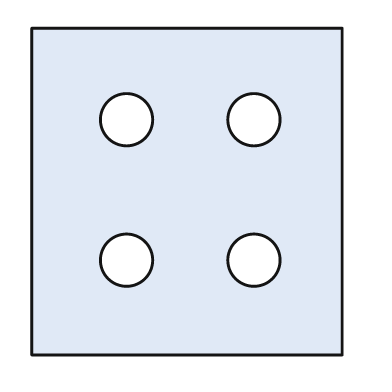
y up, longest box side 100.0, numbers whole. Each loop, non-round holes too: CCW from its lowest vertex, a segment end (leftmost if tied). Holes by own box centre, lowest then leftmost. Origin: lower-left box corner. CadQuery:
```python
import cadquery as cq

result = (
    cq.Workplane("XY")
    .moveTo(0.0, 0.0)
    .lineTo(95.0, 0.0)
    .lineTo(95.0, 100.0)
    .lineTo(0.0, 100.0)
    .close()
    .moveTo(29.0, 29.0)
    .circle(8.0)
    .moveTo(68.0, 29.0)
    .circle(8.0)
    .moveTo(29.0, 72.0)
    .circle(8.0)
    .moveTo(68.0, 72.0)
    .circle(8.0)
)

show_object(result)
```